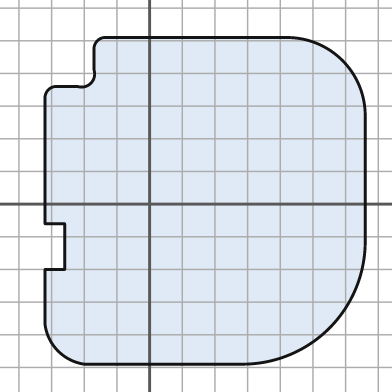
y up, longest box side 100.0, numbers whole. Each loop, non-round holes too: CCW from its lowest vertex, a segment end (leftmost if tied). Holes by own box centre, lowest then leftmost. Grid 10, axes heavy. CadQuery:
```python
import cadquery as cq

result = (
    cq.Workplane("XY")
    .moveTo(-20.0, -49.0)
    .lineTo(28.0, -49.0)
    .threePointArc((55.0, -38.0), (66.0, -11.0))
    .lineTo(66.0, 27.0)
    .threePointArc((59.0, 44.0), (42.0, 51.0))
    .lineTo(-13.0, 51.0)
    .threePointArc((-16.0, 50.0), (-17.0, 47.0))
    .lineTo(-17.0, 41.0)
    .threePointArc((-18.0, 37.0), (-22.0, 36.0))
    .lineTo(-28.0, 36.0)
    .threePointArc((-31.0, 35.0), (-32.0, 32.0))
    .lineTo(-32.0, -6.0)
    .lineTo(-26.0, -6.0)
    .lineTo(-26.0, -20.0)
    .lineTo(-32.0, -20.0)
    .lineTo(-32.0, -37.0)
    .threePointArc((-28.0, -45.0), (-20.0, -49.0))
    .close()
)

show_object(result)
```